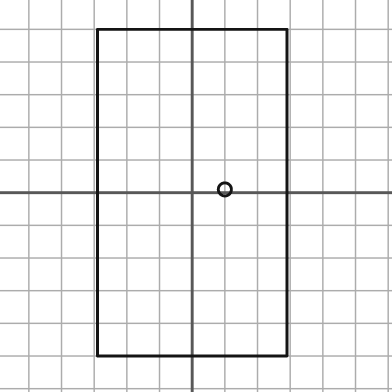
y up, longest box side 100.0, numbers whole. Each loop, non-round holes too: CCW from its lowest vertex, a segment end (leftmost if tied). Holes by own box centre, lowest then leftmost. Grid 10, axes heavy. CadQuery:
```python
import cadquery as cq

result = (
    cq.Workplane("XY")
    .moveTo(-29.0, -50.0)
    .lineTo(29.0, -50.0)
    .lineTo(29.0, 50.0)
    .lineTo(-29.0, 50.0)
    .close()
    .moveTo(10.0, 1.0)
    .circle(2.0)
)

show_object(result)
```